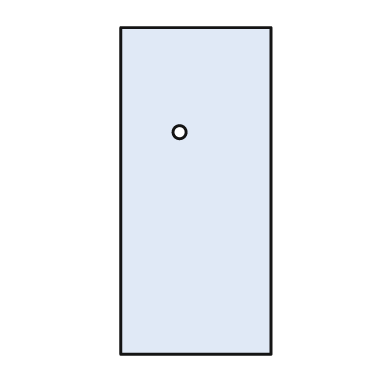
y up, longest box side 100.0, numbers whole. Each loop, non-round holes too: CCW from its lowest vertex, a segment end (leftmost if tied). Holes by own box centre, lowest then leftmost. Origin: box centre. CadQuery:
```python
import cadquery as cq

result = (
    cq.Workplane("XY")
    .moveTo(-23.0, -50.0)
    .lineTo(23.0, -50.0)
    .lineTo(23.0, 50.0)
    .lineTo(-23.0, 50.0)
    .close()
    .moveTo(-5.0, 18.0)
    .circle(2.0)
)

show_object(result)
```